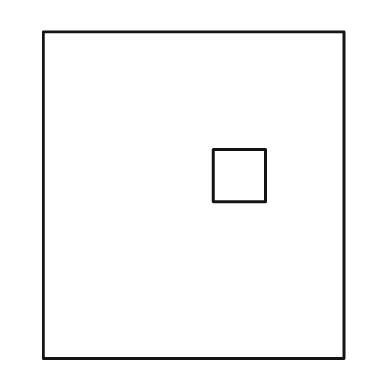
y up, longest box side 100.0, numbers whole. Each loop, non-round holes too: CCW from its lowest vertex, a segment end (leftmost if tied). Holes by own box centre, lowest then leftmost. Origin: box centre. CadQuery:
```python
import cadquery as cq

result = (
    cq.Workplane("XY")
    .moveTo(-46.0, -50.0)
    .lineTo(46.0, -50.0)
    .lineTo(46.0, 50.0)
    .lineTo(-46.0, 50.0)
    .close()
    .moveTo(6.0, -2.0)
    .lineTo(22.0, -2.0)
    .lineTo(22.0, 14.0)
    .lineTo(6.0, 14.0)
    .close()
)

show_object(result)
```